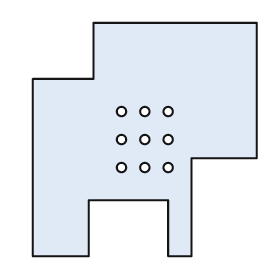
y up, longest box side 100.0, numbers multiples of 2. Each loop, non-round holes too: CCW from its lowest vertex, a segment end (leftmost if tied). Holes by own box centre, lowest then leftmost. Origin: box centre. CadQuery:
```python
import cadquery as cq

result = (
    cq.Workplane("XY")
    .moveTo(-48.0, -50.0)
    .lineTo(-24.0, -50.0)
    .lineTo(-24.0, -26.0)
    .lineTo(10.0, -26.0)
    .lineTo(10.0, -50.0)
    .lineTo(20.0, -50.0)
    .lineTo(20.0, -8.0)
    .lineTo(48.0, -8.0)
    .lineTo(48.0, 50.0)
    .lineTo(-22.0, 50.0)
    .lineTo(-22.0, 26.0)
    .lineTo(-48.0, 26.0)
    .close()
    .moveTo(-10.0, -12.0)
    .circle(2.0)
    .moveTo(0.0, -12.0)
    .circle(2.0)
    .moveTo(10.0, -12.0)
    .circle(2.0)
    .moveTo(-10.0, 0.0)
    .circle(2.0)
    .moveTo(0.0, 0.0)
    .circle(2.0)
    .moveTo(10.0, 0.0)
    .circle(2.0)
    .moveTo(-10.0, 12.0)
    .circle(2.0)
    .moveTo(0.0, 12.0)
    .circle(2.0)
    .moveTo(10.0, 12.0)
    .circle(2.0)
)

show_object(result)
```